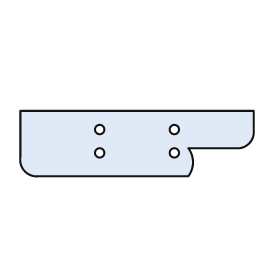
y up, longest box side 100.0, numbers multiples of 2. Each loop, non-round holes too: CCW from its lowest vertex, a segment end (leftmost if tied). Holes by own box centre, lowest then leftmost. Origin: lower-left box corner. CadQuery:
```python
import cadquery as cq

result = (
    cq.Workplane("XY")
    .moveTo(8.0, 0.0)
    .lineTo(72.0, 0.0)
    .threePointArc((74.0, 6.0), (72.0, 12.0))
    .lineTo(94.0, 12.0)
    .threePointArc((98.0, 14.0), (100.0, 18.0))
    .lineTo(100.0, 28.0)
    .lineTo(0.0, 28.0)
    .lineTo(0.0, 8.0)
    .threePointArc((2.0, 2.0), (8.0, 0.0))
    .close()
    .moveTo(34.0, 10.0)
    .circle(2.0)
    .moveTo(66.0, 10.0)
    .circle(2.0)
    .moveTo(34.0, 20.0)
    .circle(2.0)
    .moveTo(66.0, 20.0)
    .circle(2.0)
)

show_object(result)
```